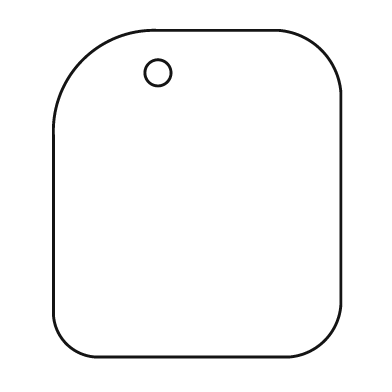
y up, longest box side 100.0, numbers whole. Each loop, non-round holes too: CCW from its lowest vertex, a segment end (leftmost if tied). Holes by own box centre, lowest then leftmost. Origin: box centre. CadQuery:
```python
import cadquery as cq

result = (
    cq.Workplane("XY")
    .moveTo(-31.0, -50.0)
    .lineTo(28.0, -50.0)
    .threePointArc((39.0, -45.0), (44.0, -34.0))
    .lineTo(44.0, 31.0)
    .threePointArc((38.0, 44.0), (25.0, 50.0))
    .lineTo(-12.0, 50.0)
    .threePointArc((-35.0, 41.0), (-44.0, 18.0))
    .lineTo(-44.0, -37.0)
    .threePointArc((-40.0, -46.0), (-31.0, -50.0))
    .close()
    .moveTo(-12.0, 37.0)
    .circle(4.0)
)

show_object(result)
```